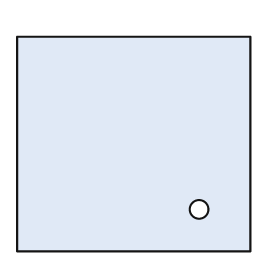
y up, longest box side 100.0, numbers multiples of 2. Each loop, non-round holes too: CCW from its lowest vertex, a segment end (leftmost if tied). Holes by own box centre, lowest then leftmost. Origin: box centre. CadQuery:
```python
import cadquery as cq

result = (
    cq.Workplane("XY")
    .moveTo(-50.0, -46.0)
    .lineTo(50.0, -46.0)
    .lineTo(50.0, 46.0)
    .lineTo(-50.0, 46.0)
    .close()
    .moveTo(28.0, -28.0)
    .circle(4.0)
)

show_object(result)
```